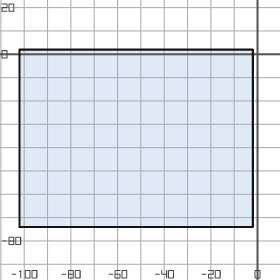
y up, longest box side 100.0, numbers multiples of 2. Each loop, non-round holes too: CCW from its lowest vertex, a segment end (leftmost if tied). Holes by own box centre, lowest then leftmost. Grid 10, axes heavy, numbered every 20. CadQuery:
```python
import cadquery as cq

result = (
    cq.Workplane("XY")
    .moveTo(-102.0, -74.0)
    .lineTo(-2.0, -74.0)
    .lineTo(-2.0, 2.0)
    .lineTo(-102.0, 2.0)
    .close()
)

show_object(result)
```